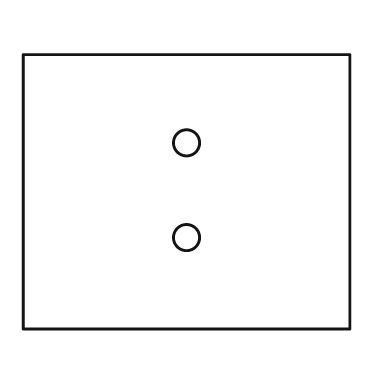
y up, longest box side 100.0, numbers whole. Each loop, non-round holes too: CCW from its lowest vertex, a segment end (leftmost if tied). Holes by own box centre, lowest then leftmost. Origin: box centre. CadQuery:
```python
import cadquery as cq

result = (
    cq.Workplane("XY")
    .moveTo(-50.0, -42.0)
    .lineTo(50.0, -42.0)
    .lineTo(50.0, 42.0)
    .lineTo(-50.0, 42.0)
    .close()
    .moveTo(0.0, -14.0)
    .circle(4.0)
    .moveTo(0.0, 15.0)
    .circle(4.0)
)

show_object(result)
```